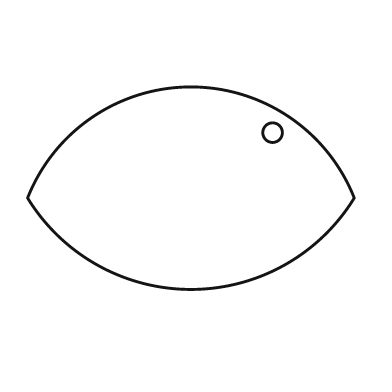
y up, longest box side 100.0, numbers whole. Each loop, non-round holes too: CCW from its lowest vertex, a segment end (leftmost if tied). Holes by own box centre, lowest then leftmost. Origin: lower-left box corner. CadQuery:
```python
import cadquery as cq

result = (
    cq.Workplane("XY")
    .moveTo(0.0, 28.0)
    .threePointArc((50.0, 0.0), (100.0, 28.0))
    .threePointArc((50.0, 62.0), (0.0, 28.0))
    .close()
    .moveTo(75.0, 48.0)
    .circle(3.0)
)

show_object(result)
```